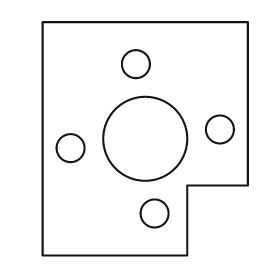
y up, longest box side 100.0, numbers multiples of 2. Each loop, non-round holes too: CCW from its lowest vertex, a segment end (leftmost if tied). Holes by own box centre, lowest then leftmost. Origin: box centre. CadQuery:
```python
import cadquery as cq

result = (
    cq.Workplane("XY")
    .moveTo(-44.0, -50.0)
    .lineTo(18.0, -50.0)
    .lineTo(18.0, -20.0)
    .lineTo(44.0, -20.0)
    .lineTo(44.0, 50.0)
    .lineTo(-44.0, 50.0)
    .close()
    .moveTo(4.0, -32.0)
    .circle(6.0)
    .moveTo(-32.0, -4.0)
    .circle(6.0)
    .moveTo(0.0, 0.0)
    .circle(18.0)
    .moveTo(32.0, 4.0)
    .circle(6.0)
    .moveTo(-4.0, 32.0)
    .circle(6.0)
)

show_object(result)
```